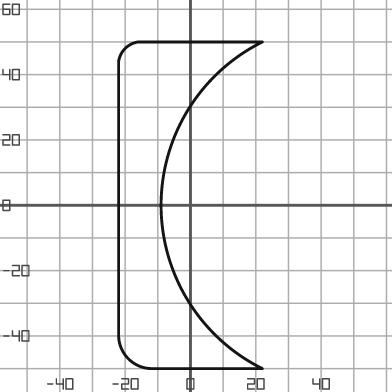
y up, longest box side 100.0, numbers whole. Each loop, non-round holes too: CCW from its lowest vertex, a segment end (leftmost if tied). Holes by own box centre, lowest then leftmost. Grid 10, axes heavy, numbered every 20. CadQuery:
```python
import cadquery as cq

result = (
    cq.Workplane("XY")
    .moveTo(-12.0, -50.0)
    .lineTo(22.0, -50.0)
    .threePointArc((-9.0, 0.0), (22.0, 50.0))
    .lineTo(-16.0, 50.0)
    .threePointArc((-20.0, 48.0), (-22.0, 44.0))
    .lineTo(-22.0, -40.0)
    .threePointArc((-19.0, -47.0), (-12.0, -50.0))
    .close()
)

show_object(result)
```